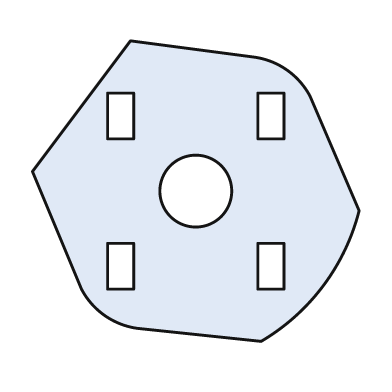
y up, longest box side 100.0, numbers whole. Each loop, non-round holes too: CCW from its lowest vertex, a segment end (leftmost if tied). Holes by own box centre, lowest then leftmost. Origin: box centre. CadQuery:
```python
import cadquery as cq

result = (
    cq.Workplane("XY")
    .moveTo(20.0, -46.0)
    .threePointArc((39.0, -29.0), (50.0, -6.0))
    .lineTo(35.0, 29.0)
    .threePointArc((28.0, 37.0), (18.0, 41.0))
    .lineTo(-20.0, 46.0)
    .lineTo(-50.0, 6.0)
    .lineTo(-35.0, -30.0)
    .threePointArc((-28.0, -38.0), (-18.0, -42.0))
    .close()
    .moveTo(-27.0, -30.0)
    .lineTo(-19.0, -30.0)
    .lineTo(-19.0, -16.0)
    .lineTo(-27.0, -16.0)
    .close()
    .moveTo(19.0, -30.0)
    .lineTo(27.0, -30.0)
    .lineTo(27.0, -16.0)
    .lineTo(19.0, -16.0)
    .close()
    .moveTo(0.0, 0.0)
    .circle(11.0)
    .moveTo(-27.0, 16.0)
    .lineTo(-19.0, 16.0)
    .lineTo(-19.0, 30.0)
    .lineTo(-27.0, 30.0)
    .close()
    .moveTo(19.0, 16.0)
    .lineTo(27.0, 16.0)
    .lineTo(27.0, 30.0)
    .lineTo(19.0, 30.0)
    .close()
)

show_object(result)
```